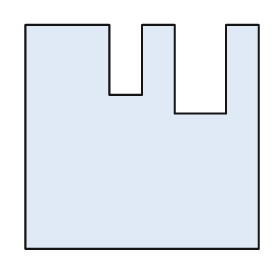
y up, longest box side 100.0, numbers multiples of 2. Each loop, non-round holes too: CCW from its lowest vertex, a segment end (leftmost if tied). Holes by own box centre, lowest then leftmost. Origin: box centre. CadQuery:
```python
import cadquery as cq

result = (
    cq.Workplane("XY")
    .moveTo(-50.0, -48.0)
    .lineTo(50.0, -48.0)
    .lineTo(50.0, 48.0)
    .lineTo(36.0, 48.0)
    .lineTo(36.0, 10.0)
    .lineTo(14.0, 10.0)
    .lineTo(14.0, 48.0)
    .lineTo(0.0, 48.0)
    .lineTo(0.0, 18.0)
    .lineTo(-14.0, 18.0)
    .lineTo(-14.0, 48.0)
    .lineTo(-50.0, 48.0)
    .close()
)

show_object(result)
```